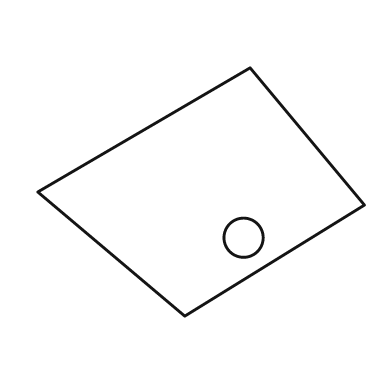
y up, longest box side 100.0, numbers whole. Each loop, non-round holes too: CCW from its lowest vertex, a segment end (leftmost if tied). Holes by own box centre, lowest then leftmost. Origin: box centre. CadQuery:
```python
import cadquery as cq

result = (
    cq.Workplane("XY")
    .moveTo(-5.0, -38.0)
    .lineTo(50.0, -4.0)
    .lineTo(15.0, 38.0)
    .lineTo(-50.0, 0.0)
    .close()
    .moveTo(13.0, -14.0)
    .circle(6.0)
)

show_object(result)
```